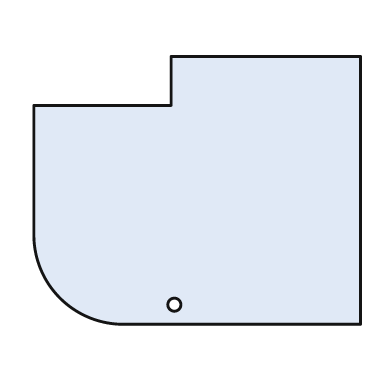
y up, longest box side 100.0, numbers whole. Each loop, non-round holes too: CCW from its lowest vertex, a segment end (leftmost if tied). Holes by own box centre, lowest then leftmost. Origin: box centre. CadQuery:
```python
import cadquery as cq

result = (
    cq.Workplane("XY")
    .moveTo(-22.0, -41.0)
    .lineTo(50.0, -41.0)
    .lineTo(50.0, 41.0)
    .lineTo(-8.0, 41.0)
    .lineTo(-8.0, 26.0)
    .lineTo(-50.0, 26.0)
    .lineTo(-50.0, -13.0)
    .threePointArc((-42.0, -33.0), (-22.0, -41.0))
    .close()
    .moveTo(-7.0, -35.0)
    .circle(2.0)
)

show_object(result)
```